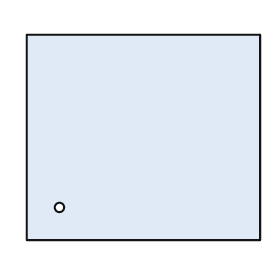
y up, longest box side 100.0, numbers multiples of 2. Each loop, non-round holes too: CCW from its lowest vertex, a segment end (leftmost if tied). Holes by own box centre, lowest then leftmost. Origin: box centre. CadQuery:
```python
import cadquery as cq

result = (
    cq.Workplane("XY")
    .moveTo(-50.0, -44.0)
    .lineTo(50.0, -44.0)
    .lineTo(50.0, 44.0)
    .lineTo(-50.0, 44.0)
    .close()
    .moveTo(-36.0, -30.0)
    .circle(2.0)
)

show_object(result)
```